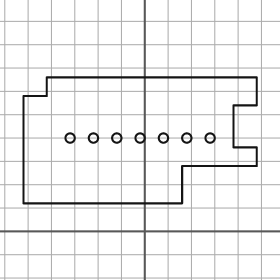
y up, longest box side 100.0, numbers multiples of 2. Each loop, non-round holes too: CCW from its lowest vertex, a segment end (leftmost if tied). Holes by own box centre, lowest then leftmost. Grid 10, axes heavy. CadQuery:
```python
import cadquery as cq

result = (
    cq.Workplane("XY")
    .moveTo(-52.0, 12.0)
    .lineTo(16.0, 12.0)
    .lineTo(16.0, 28.0)
    .lineTo(48.0, 28.0)
    .lineTo(48.0, 36.0)
    .lineTo(38.0, 36.0)
    .lineTo(38.0, 54.0)
    .lineTo(48.0, 54.0)
    .lineTo(48.0, 66.0)
    .lineTo(-42.0, 66.0)
    .lineTo(-42.0, 58.0)
    .lineTo(-52.0, 58.0)
    .close()
    .moveTo(-32.0, 40.0)
    .circle(2.0)
    .moveTo(-22.0, 40.0)
    .circle(2.0)
    .moveTo(-12.0, 40.0)
    .circle(2.0)
    .moveTo(-2.0, 40.0)
    .circle(2.0)
    .moveTo(8.0, 40.0)
    .circle(2.0)
    .moveTo(18.0, 40.0)
    .circle(2.0)
    .moveTo(28.0, 40.0)
    .circle(2.0)
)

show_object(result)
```